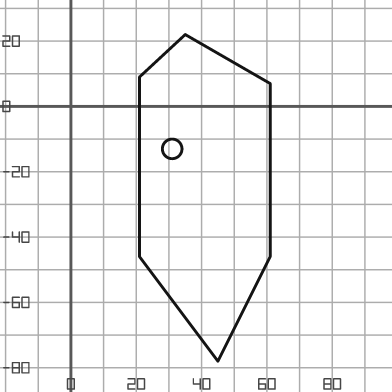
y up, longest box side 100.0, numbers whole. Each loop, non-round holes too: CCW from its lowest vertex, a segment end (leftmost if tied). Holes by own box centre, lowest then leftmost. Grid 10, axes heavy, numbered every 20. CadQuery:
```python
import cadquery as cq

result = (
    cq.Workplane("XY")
    .moveTo(45.0, -78.0)
    .lineTo(61.0, -46.0)
    .lineTo(61.0, 7.0)
    .lineTo(35.0, 22.0)
    .lineTo(21.0, 9.0)
    .lineTo(21.0, -46.0)
    .close()
    .moveTo(31.0, -13.0)
    .circle(3.0)
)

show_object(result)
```